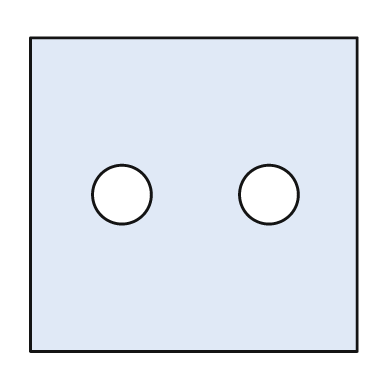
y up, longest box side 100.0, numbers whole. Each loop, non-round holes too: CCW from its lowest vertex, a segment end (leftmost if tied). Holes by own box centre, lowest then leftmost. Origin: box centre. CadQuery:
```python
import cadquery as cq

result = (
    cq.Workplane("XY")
    .moveTo(-50.0, -48.0)
    .lineTo(50.0, -48.0)
    .lineTo(50.0, 48.0)
    .lineTo(-50.0, 48.0)
    .close()
    .moveTo(-22.0, 0.0)
    .circle(9.0)
    .moveTo(23.0, 0.0)
    .circle(9.0)
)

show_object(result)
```